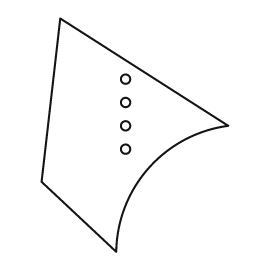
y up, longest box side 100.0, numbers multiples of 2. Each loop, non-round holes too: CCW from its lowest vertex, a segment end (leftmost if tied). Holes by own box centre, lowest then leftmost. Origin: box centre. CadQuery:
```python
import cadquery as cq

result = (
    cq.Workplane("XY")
    .moveTo(-8.0, -50.0)
    .threePointArc((6.0, -14.0), (40.0, 4.0))
    .lineTo(-32.0, 50.0)
    .lineTo(-40.0, -20.0)
    .close()
    .moveTo(-4.0, -6.0)
    .circle(2.0)
    .moveTo(-4.0, 4.0)
    .circle(2.0)
    .moveTo(-4.0, 14.0)
    .circle(2.0)
    .moveTo(-4.0, 24.0)
    .circle(2.0)
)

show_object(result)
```